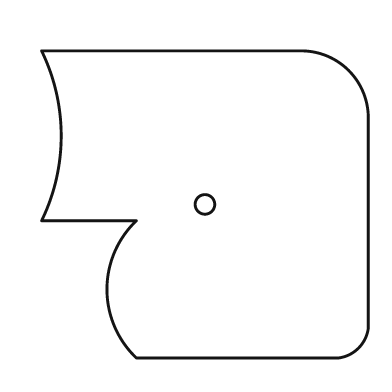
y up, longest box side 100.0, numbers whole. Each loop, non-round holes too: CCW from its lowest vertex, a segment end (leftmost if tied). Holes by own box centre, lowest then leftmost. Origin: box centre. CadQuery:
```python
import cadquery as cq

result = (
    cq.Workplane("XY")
    .moveTo(-21.0, -47.0)
    .lineTo(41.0, -47.0)
    .threePointArc((47.0, -44.0), (50.0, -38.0))
    .lineTo(50.0, 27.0)
    .threePointArc((44.0, 41.0), (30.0, 47.0))
    .lineTo(-50.0, 47.0)
    .threePointArc((-44.0, 21.0), (-50.0, -5.0))
    .lineTo(-21.0, -5.0)
    .threePointArc((-30.0, -26.0), (-21.0, -47.0))
    .close()
    .moveTo(0.0, 0.0)
    .circle(3.0)
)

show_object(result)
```